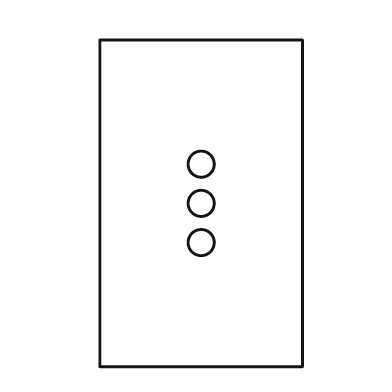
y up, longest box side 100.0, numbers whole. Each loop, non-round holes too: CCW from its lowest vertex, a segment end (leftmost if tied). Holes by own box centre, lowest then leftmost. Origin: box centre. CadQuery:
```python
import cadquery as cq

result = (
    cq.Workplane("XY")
    .moveTo(-31.0, -50.0)
    .lineTo(31.0, -50.0)
    .lineTo(31.0, 50.0)
    .lineTo(-31.0, 50.0)
    .close()
    .moveTo(0.0, -12.0)
    .circle(4.0)
    .moveTo(0.0, 0.0)
    .circle(4.0)
    .moveTo(0.0, 12.0)
    .circle(4.0)
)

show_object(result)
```